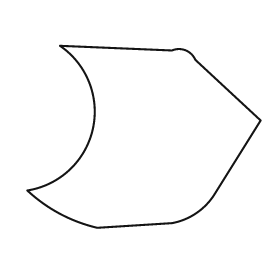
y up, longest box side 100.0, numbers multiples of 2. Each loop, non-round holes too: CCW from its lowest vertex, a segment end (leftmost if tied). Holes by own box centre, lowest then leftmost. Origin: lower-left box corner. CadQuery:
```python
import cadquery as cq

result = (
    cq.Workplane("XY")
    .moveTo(30.0, 0.0)
    .lineTo(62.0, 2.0)
    .threePointArc((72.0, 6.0), (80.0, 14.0))
    .lineTo(100.0, 46.0)
    .lineTo(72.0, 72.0)
    .threePointArc((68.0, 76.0), (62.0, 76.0))
    .lineTo(14.0, 78.0)
    .threePointArc((28.0, 42.0), (0.0, 16.0))
    .threePointArc((14.0, 6.0), (30.0, 0.0))
    .close()
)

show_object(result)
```